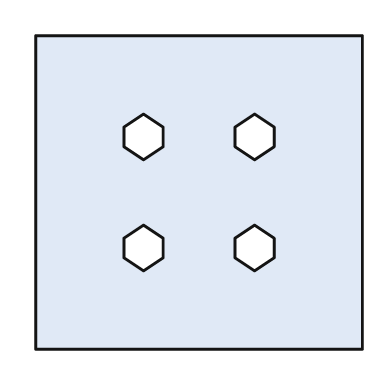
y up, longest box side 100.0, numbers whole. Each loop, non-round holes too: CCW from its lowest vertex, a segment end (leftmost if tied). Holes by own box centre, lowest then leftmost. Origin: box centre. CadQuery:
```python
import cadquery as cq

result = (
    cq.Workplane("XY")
    .moveTo(-50.0, -48.0)
    .lineTo(50.0, -48.0)
    .lineTo(50.0, 48.0)
    .lineTo(-50.0, 48.0)
    .close()
    .moveTo(-17.0, -24.0)
    .lineTo(-11.0, -20.0)
    .lineTo(-11.0, -14.0)
    .lineTo(-17.0, -10.0)
    .lineTo(-23.0, -14.0)
    .lineTo(-23.0, -20.0)
    .close()
    .moveTo(17.0, -24.0)
    .lineTo(23.0, -20.0)
    .lineTo(23.0, -14.0)
    .lineTo(17.0, -10.0)
    .lineTo(11.0, -14.0)
    .lineTo(11.0, -20.0)
    .close()
    .moveTo(-17.0, 10.0)
    .lineTo(-11.0, 14.0)
    .lineTo(-11.0, 20.0)
    .lineTo(-17.0, 24.0)
    .lineTo(-23.0, 20.0)
    .lineTo(-23.0, 14.0)
    .close()
    .moveTo(17.0, 10.0)
    .lineTo(23.0, 14.0)
    .lineTo(23.0, 20.0)
    .lineTo(17.0, 24.0)
    .lineTo(11.0, 20.0)
    .lineTo(11.0, 14.0)
    .close()
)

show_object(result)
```